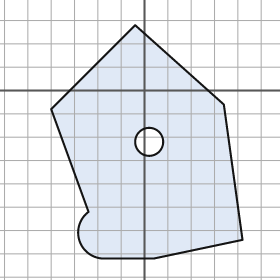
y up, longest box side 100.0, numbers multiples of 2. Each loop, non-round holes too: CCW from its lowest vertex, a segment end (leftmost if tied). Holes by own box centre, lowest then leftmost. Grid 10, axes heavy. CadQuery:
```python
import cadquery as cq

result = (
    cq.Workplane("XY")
    .moveTo(-18.0, -72.0)
    .lineTo(4.0, -72.0)
    .lineTo(42.0, -64.0)
    .lineTo(34.0, -6.0)
    .lineTo(-4.0, 28.0)
    .lineTo(-40.0, -8.0)
    .lineTo(-24.0, -52.0)
    .threePointArc((-28.0, -64.0), (-18.0, -72.0))
    .close()
    .moveTo(2.0, -22.0)
    .circle(6.0)
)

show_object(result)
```